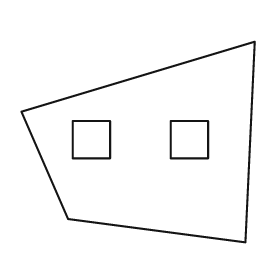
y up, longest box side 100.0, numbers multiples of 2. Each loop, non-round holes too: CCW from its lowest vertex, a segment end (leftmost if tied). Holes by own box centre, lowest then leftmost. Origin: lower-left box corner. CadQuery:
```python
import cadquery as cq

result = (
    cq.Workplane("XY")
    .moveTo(96.0, 0.0)
    .lineTo(100.0, 86.0)
    .lineTo(0.0, 56.0)
    .lineTo(20.0, 10.0)
    .close()
    .moveTo(22.0, 36.0)
    .lineTo(38.0, 36.0)
    .lineTo(38.0, 52.0)
    .lineTo(22.0, 52.0)
    .close()
    .moveTo(64.0, 36.0)
    .lineTo(80.0, 36.0)
    .lineTo(80.0, 52.0)
    .lineTo(64.0, 52.0)
    .close()
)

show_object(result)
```